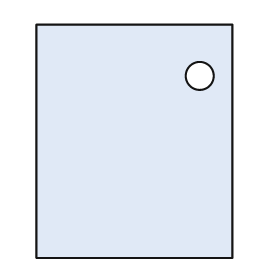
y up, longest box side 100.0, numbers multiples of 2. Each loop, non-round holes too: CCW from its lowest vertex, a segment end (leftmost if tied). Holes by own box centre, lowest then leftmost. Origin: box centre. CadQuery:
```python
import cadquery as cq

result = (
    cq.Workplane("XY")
    .moveTo(-42.0, -50.0)
    .lineTo(42.0, -50.0)
    .lineTo(42.0, 50.0)
    .lineTo(-42.0, 50.0)
    .close()
    .moveTo(28.0, 28.0)
    .circle(6.0)
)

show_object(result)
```